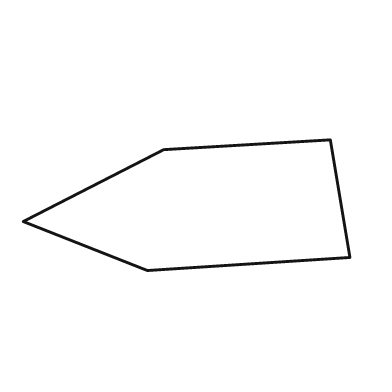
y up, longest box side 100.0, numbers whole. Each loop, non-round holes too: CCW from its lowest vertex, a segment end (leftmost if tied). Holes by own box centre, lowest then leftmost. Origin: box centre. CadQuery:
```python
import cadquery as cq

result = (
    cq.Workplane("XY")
    .moveTo(-12.0, -20.0)
    .lineTo(50.0, -16.0)
    .lineTo(44.0, 20.0)
    .lineTo(-7.0, 17.0)
    .lineTo(-50.0, -5.0)
    .close()
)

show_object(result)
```